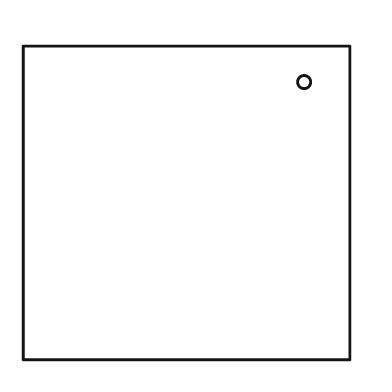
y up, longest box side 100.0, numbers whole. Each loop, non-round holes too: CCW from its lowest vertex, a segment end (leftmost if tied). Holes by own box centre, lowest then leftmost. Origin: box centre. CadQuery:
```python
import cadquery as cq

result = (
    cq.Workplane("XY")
    .moveTo(-50.0, -48.0)
    .lineTo(50.0, -48.0)
    .lineTo(50.0, 48.0)
    .lineTo(-50.0, 48.0)
    .close()
    .moveTo(36.0, 37.0)
    .circle(2.0)
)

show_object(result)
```